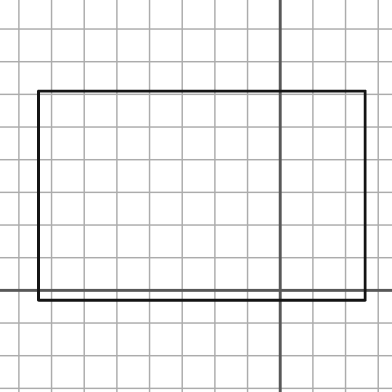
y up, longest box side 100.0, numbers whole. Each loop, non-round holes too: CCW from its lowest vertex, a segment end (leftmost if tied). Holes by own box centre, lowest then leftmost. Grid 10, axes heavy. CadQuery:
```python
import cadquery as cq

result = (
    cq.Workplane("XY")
    .moveTo(-74.0, -3.0)
    .lineTo(26.0, -3.0)
    .lineTo(26.0, 61.0)
    .lineTo(-74.0, 61.0)
    .close()
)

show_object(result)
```